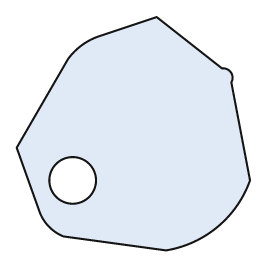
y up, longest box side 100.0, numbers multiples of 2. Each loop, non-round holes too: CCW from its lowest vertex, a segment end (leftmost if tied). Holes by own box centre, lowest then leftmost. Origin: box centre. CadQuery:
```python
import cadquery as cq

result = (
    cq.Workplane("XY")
    .moveTo(14.0, -50.0)
    .threePointArc((36.0, -40.0), (50.0, -20.0))
    .lineTo(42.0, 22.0)
    .threePointArc((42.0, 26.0), (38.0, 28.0))
    .lineTo(10.0, 50.0)
    .lineTo(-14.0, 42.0)
    .threePointArc((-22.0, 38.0), (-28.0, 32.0))
    .lineTo(-50.0, -6.0)
    .lineTo(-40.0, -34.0)
    .threePointArc((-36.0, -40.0), (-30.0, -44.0))
    .close()
    .moveTo(-26.0, -20.0)
    .circle(10.0)
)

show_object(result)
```